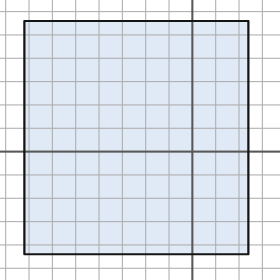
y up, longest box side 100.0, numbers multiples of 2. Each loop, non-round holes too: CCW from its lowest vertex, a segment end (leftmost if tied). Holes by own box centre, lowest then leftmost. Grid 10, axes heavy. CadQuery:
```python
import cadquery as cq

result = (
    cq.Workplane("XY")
    .moveTo(-72.0, -44.0)
    .lineTo(24.0, -44.0)
    .lineTo(24.0, 56.0)
    .lineTo(-72.0, 56.0)
    .close()
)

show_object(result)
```